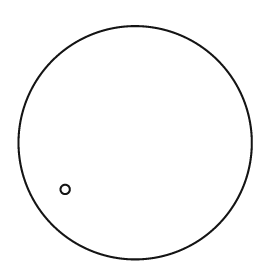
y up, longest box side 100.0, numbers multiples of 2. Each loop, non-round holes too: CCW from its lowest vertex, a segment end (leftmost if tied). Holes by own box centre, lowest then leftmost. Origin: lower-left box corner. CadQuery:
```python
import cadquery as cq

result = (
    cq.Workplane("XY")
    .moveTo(50.0, 50.0)
    .circle(50.0)
    .moveTo(20.0, 30.0)
    .circle(2.0)
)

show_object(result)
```